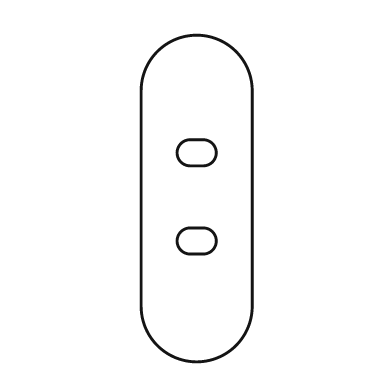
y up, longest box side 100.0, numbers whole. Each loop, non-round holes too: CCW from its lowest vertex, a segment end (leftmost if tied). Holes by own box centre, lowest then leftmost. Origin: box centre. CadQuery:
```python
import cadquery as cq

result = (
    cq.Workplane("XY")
    .moveTo(-17.0, -33.0)
    .threePointArc((0.0, -50.0), (17.0, -33.0))
    .lineTo(17.0, 33.0)
    .threePointArc((0.0, 50.0), (-17.0, 33.0))
    .close()
    .moveTo(-2.0, -17.0)
    .lineTo(2.0, -17.0)
    .threePointArc((6.0, -13.0), (2.0, -9.0))
    .lineTo(-2.0, -9.0)
    .threePointArc((-6.0, -13.0), (-2.0, -17.0))
    .close()
    .moveTo(-2.0, 10.0)
    .lineTo(2.0, 10.0)
    .threePointArc((6.0, 14.0), (2.0, 18.0))
    .lineTo(-2.0, 18.0)
    .threePointArc((-6.0, 14.0), (-2.0, 10.0))
    .close()
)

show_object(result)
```